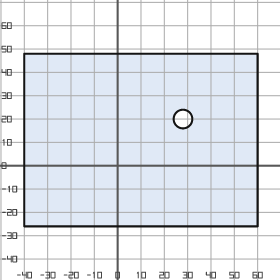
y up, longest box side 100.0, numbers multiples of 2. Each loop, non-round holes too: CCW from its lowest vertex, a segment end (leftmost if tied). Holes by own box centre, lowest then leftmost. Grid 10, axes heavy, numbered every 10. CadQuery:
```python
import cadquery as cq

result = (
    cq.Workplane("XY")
    .moveTo(-40.0, -26.0)
    .lineTo(60.0, -26.0)
    .lineTo(60.0, 48.0)
    .lineTo(-40.0, 48.0)
    .close()
    .moveTo(28.0, 20.0)
    .circle(4.0)
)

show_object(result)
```